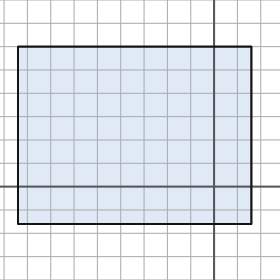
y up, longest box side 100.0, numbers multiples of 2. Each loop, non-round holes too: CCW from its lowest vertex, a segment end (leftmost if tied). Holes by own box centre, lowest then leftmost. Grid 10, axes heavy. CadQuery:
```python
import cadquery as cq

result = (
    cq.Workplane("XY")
    .moveTo(-84.0, -16.0)
    .lineTo(16.0, -16.0)
    .lineTo(16.0, 60.0)
    .lineTo(-84.0, 60.0)
    .close()
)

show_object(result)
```